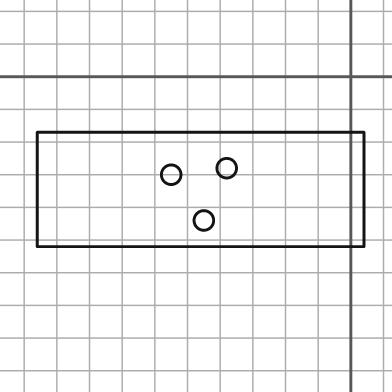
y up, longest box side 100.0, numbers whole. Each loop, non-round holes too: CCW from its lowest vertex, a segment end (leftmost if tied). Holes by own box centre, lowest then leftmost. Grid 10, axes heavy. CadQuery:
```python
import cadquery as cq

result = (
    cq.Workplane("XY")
    .moveTo(-96.0, -52.0)
    .lineTo(4.0, -52.0)
    .lineTo(4.0, -17.0)
    .lineTo(-96.0, -17.0)
    .close()
    .moveTo(-45.0, -44.0)
    .circle(3.0)
    .moveTo(-55.0, -30.0)
    .circle(3.0)
    .moveTo(-38.0, -28.0)
    .circle(3.0)
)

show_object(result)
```